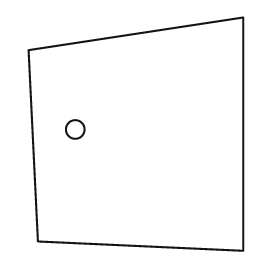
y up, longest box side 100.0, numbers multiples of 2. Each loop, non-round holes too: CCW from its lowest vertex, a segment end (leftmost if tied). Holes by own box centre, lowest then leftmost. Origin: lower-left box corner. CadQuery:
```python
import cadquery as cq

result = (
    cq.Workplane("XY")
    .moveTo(92.0, 0.0)
    .lineTo(92.0, 100.0)
    .lineTo(0.0, 86.0)
    .lineTo(4.0, 4.0)
    .close()
    .moveTo(20.0, 52.0)
    .circle(4.0)
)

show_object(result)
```